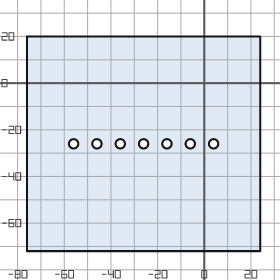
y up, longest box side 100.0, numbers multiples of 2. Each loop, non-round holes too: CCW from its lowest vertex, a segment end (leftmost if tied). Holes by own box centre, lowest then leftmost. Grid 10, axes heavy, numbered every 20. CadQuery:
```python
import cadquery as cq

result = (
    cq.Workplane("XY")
    .moveTo(-76.0, -72.0)
    .lineTo(24.0, -72.0)
    .lineTo(24.0, 20.0)
    .lineTo(-76.0, 20.0)
    .close()
    .moveTo(-56.0, -26.0)
    .circle(2.0)
    .moveTo(-46.0, -26.0)
    .circle(2.0)
    .moveTo(-36.0, -26.0)
    .circle(2.0)
    .moveTo(-26.0, -26.0)
    .circle(2.0)
    .moveTo(-16.0, -26.0)
    .circle(2.0)
    .moveTo(-6.0, -26.0)
    .circle(2.0)
    .moveTo(4.0, -26.0)
    .circle(2.0)
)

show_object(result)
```